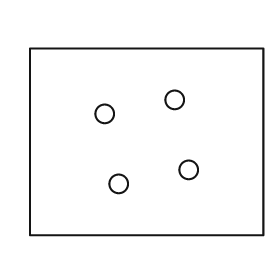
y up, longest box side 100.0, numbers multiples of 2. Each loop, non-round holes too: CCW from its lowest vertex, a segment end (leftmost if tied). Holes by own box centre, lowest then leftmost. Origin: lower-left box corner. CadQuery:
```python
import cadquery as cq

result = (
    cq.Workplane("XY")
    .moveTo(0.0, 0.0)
    .lineTo(100.0, 0.0)
    .lineTo(100.0, 80.0)
    .lineTo(0.0, 80.0)
    .close()
    .moveTo(38.0, 22.0)
    .circle(4.0)
    .moveTo(68.0, 28.0)
    .circle(4.0)
    .moveTo(32.0, 52.0)
    .circle(4.0)
    .moveTo(62.0, 58.0)
    .circle(4.0)
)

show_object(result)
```